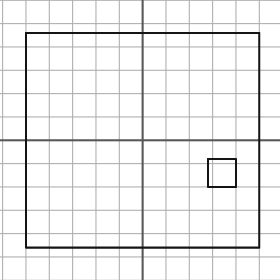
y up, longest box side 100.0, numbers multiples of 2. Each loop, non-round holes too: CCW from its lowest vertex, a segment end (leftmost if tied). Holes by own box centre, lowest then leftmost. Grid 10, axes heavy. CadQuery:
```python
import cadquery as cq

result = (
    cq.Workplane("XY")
    .moveTo(-50.0, -46.0)
    .lineTo(50.0, -46.0)
    .lineTo(50.0, 46.0)
    .lineTo(-50.0, 46.0)
    .close()
    .moveTo(28.0, -20.0)
    .lineTo(40.0, -20.0)
    .lineTo(40.0, -8.0)
    .lineTo(28.0, -8.0)
    .close()
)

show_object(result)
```